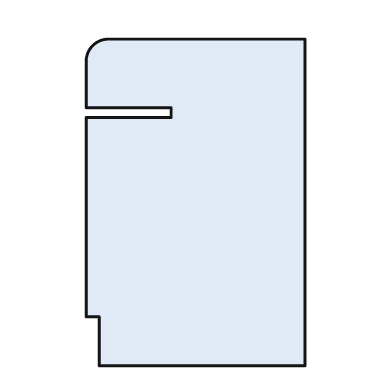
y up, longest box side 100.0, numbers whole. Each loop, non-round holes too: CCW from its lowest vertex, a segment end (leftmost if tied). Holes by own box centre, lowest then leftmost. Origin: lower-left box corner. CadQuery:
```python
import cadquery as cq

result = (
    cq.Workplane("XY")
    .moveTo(4.0, 0.0)
    .lineTo(67.0, 0.0)
    .lineTo(67.0, 100.0)
    .lineTo(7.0, 100.0)
    .threePointArc((2.0, 98.0), (0.0, 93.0))
    .lineTo(0.0, 79.0)
    .lineTo(26.0, 79.0)
    .lineTo(26.0, 76.0)
    .lineTo(0.0, 76.0)
    .lineTo(0.0, 15.0)
    .lineTo(4.0, 15.0)
    .close()
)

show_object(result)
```